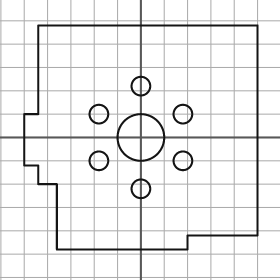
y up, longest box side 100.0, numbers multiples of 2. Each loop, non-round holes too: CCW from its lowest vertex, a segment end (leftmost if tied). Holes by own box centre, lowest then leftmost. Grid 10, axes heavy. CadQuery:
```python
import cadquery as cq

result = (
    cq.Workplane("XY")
    .moveTo(-36.0, -48.0)
    .lineTo(20.0, -48.0)
    .lineTo(20.0, -42.0)
    .lineTo(50.0, -42.0)
    .lineTo(50.0, 48.0)
    .lineTo(-44.0, 48.0)
    .lineTo(-44.0, 10.0)
    .lineTo(-50.0, 10.0)
    .lineTo(-50.0, -12.0)
    .lineTo(-44.0, -12.0)
    .lineTo(-44.0, -20.0)
    .lineTo(-36.0, -20.0)
    .close()
    .moveTo(0.0, -22.0)
    .circle(4.0)
    .moveTo(-18.0, -10.0)
    .circle(4.0)
    .moveTo(18.0, -10.0)
    .circle(4.0)
    .moveTo(0.0, 0.0)
    .circle(10.0)
    .moveTo(-18.0, 10.0)
    .circle(4.0)
    .moveTo(18.0, 10.0)
    .circle(4.0)
    .moveTo(0.0, 22.0)
    .circle(4.0)
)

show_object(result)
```